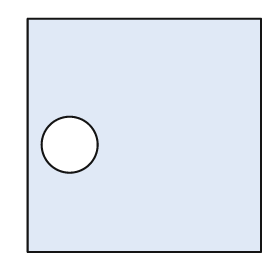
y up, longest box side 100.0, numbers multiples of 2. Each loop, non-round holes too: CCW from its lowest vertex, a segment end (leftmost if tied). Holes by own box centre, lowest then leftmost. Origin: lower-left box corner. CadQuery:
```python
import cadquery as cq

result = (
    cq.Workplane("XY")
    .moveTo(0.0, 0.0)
    .lineTo(100.0, 0.0)
    .lineTo(100.0, 100.0)
    .lineTo(0.0, 100.0)
    .close()
    .moveTo(18.0, 46.0)
    .circle(12.0)
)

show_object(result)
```